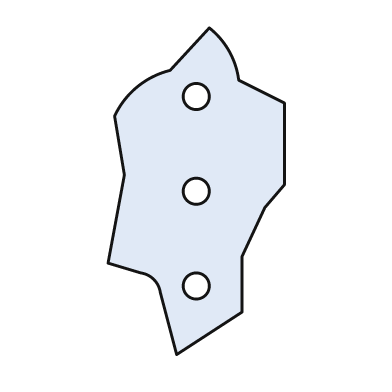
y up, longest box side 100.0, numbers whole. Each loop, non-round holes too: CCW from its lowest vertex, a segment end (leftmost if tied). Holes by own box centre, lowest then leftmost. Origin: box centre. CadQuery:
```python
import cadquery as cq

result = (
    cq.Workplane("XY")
    .moveTo(-6.0, -50.0)
    .lineTo(14.0, -37.0)
    .lineTo(14.0, -20.0)
    .lineTo(21.0, -5.0)
    .lineTo(27.0, 2.0)
    .lineTo(27.0, 27.0)
    .lineTo(13.0, 34.0)
    .threePointArc((10.0, 43.0), (4.0, 50.0))
    .lineTo(-8.0, 37.0)
    .threePointArc((-18.0, 32.0), (-25.0, 23.0))
    .lineTo(-22.0, 5.0)
    .lineTo(-27.0, -22.0)
    .lineTo(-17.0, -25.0)
    .threePointArc((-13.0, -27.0), (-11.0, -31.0))
    .close()
    .moveTo(0.0, -29.0)
    .circle(4.0)
    .moveTo(0.0, 0.0)
    .circle(4.0)
    .moveTo(0.0, 29.0)
    .circle(4.0)
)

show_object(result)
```